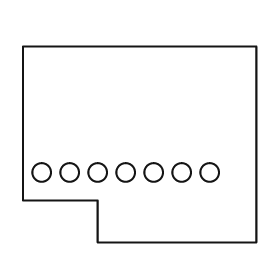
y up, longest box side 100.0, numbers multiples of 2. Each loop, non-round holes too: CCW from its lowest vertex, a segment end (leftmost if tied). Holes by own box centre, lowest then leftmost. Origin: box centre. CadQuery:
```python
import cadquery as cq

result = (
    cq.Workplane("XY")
    .moveTo(-18.0, -42.0)
    .lineTo(50.0, -42.0)
    .lineTo(50.0, 42.0)
    .lineTo(-50.0, 42.0)
    .lineTo(-50.0, -24.0)
    .lineTo(-18.0, -24.0)
    .close()
    .moveTo(-42.0, -12.0)
    .circle(4.0)
    .moveTo(-30.0, -12.0)
    .circle(4.0)
    .moveTo(-18.0, -12.0)
    .circle(4.0)
    .moveTo(-6.0, -12.0)
    .circle(4.0)
    .moveTo(6.0, -12.0)
    .circle(4.0)
    .moveTo(18.0, -12.0)
    .circle(4.0)
    .moveTo(30.0, -12.0)
    .circle(4.0)
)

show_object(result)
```